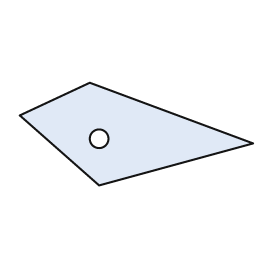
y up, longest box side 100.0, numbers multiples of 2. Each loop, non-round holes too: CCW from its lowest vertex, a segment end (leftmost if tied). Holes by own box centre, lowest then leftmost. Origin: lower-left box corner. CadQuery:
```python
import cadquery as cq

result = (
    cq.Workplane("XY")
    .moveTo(34.0, 0.0)
    .lineTo(100.0, 18.0)
    .lineTo(30.0, 44.0)
    .lineTo(0.0, 30.0)
    .close()
    .moveTo(34.0, 20.0)
    .circle(4.0)
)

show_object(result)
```